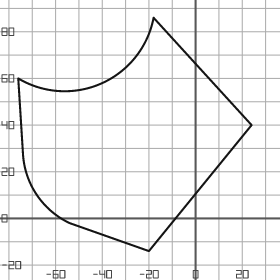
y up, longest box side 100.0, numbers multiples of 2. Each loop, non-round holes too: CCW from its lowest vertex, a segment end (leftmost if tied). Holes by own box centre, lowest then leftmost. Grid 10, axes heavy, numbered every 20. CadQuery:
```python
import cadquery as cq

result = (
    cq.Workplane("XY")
    .moveTo(-20.0, -14.0)
    .lineTo(24.0, 40.0)
    .lineTo(-18.0, 86.0)
    .threePointArc((-40.0, 58.0), (-76.0, 60.0))
    .lineTo(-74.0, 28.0)
    .threePointArc((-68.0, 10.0), (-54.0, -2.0))
    .close()
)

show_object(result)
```